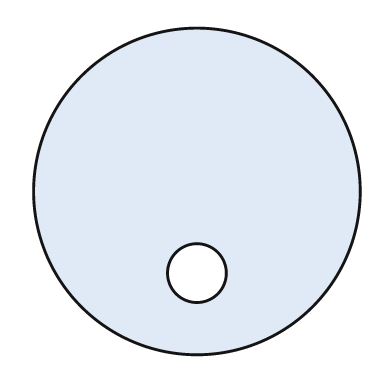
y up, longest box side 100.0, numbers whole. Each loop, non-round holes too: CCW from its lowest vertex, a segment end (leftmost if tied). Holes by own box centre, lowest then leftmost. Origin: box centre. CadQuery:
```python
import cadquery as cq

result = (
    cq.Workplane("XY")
    .moveTo(0.0, 0.0)
    .circle(50.0)
    .moveTo(0.0, -25.0)
    .circle(9.0)
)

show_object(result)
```